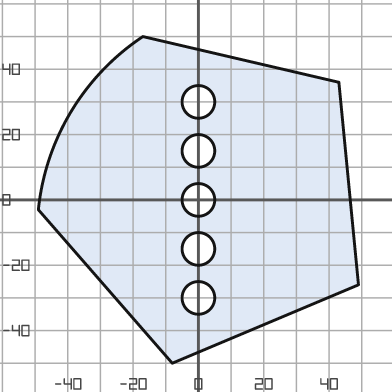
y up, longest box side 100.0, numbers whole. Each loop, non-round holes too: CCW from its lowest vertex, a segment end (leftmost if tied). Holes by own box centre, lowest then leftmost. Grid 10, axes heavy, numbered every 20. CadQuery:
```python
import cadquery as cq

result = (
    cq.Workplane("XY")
    .moveTo(-8.0, -50.0)
    .lineTo(49.0, -26.0)
    .lineTo(43.0, 36.0)
    .lineTo(-17.0, 50.0)
    .threePointArc((-39.0, 27.0), (-49.0, -3.0))
    .close()
    .moveTo(0.0, -30.0)
    .circle(5.0)
    .moveTo(0.0, -15.0)
    .circle(5.0)
    .moveTo(0.0, 0.0)
    .circle(5.0)
    .moveTo(0.0, 15.0)
    .circle(5.0)
    .moveTo(0.0, 30.0)
    .circle(5.0)
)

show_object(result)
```